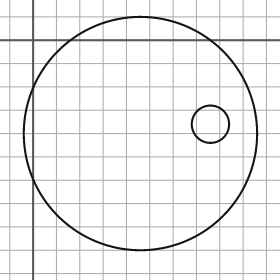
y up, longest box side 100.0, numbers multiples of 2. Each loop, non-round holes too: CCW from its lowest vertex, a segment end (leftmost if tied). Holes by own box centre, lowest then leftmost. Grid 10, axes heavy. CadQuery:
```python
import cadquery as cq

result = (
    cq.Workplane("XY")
    .moveTo(46.0, -40.0)
    .circle(50.0)
    .moveTo(76.0, -36.0)
    .circle(8.0)
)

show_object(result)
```